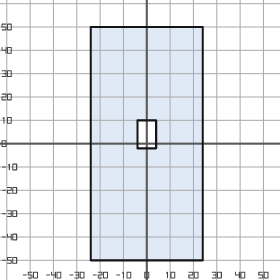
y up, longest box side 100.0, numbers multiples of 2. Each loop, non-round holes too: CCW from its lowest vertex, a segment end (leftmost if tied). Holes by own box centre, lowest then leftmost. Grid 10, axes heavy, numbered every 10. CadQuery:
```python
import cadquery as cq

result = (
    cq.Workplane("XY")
    .moveTo(-24.0, -50.0)
    .lineTo(24.0, -50.0)
    .lineTo(24.0, 50.0)
    .lineTo(-24.0, 50.0)
    .close()
    .moveTo(-4.0, -2.0)
    .lineTo(4.0, -2.0)
    .lineTo(4.0, 10.0)
    .lineTo(-4.0, 10.0)
    .close()
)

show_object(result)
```